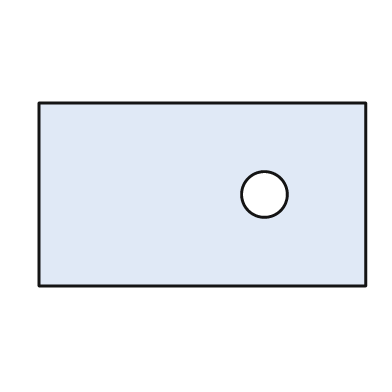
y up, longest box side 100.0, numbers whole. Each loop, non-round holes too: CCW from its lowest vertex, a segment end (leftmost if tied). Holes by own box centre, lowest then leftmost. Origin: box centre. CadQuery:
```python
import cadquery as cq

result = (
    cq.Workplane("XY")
    .moveTo(-50.0, -28.0)
    .lineTo(50.0, -28.0)
    .lineTo(50.0, 28.0)
    .lineTo(-50.0, 28.0)
    .close()
    .moveTo(19.0, 0.0)
    .circle(7.0)
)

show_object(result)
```